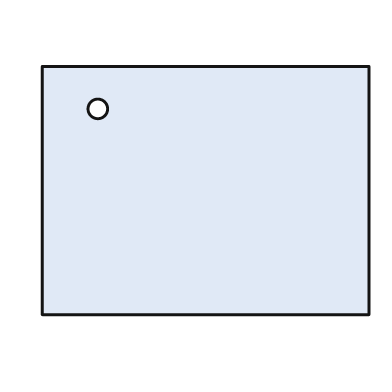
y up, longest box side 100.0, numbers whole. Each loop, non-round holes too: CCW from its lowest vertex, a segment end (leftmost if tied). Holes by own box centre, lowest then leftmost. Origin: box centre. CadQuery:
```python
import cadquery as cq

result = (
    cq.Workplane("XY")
    .moveTo(-50.0, -38.0)
    .lineTo(50.0, -38.0)
    .lineTo(50.0, 38.0)
    .lineTo(-50.0, 38.0)
    .close()
    .moveTo(-33.0, 25.0)
    .circle(3.0)
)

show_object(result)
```